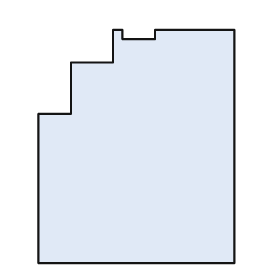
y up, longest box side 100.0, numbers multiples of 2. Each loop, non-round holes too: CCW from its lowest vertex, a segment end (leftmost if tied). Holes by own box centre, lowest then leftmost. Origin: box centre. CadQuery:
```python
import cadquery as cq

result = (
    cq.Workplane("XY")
    .moveTo(-42.0, -50.0)
    .lineTo(42.0, -50.0)
    .lineTo(42.0, 50.0)
    .lineTo(8.0, 50.0)
    .lineTo(8.0, 46.0)
    .lineTo(-6.0, 46.0)
    .lineTo(-6.0, 50.0)
    .lineTo(-10.0, 50.0)
    .lineTo(-10.0, 36.0)
    .lineTo(-28.0, 36.0)
    .lineTo(-28.0, 14.0)
    .lineTo(-42.0, 14.0)
    .close()
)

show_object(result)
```